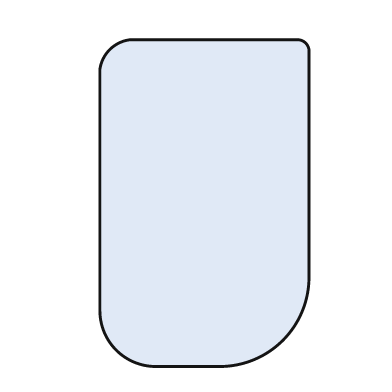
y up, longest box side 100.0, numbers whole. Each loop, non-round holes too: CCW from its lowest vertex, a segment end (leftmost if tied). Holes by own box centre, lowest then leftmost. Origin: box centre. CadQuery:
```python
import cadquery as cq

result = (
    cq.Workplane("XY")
    .moveTo(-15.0, -50.0)
    .lineTo(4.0, -50.0)
    .threePointArc((24.0, -42.0), (32.0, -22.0))
    .lineTo(32.0, 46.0)
    .threePointArc((31.0, 49.0), (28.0, 50.0))
    .lineTo(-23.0, 50.0)
    .threePointArc((-29.0, 47.0), (-32.0, 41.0))
    .lineTo(-32.0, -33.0)
    .threePointArc((-27.0, -45.0), (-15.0, -50.0))
    .close()
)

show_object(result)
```